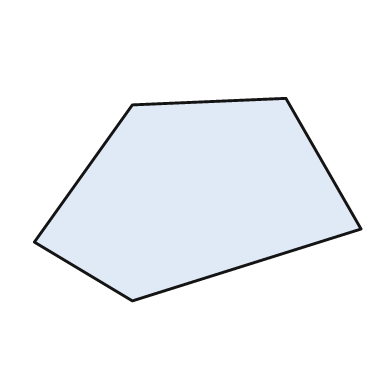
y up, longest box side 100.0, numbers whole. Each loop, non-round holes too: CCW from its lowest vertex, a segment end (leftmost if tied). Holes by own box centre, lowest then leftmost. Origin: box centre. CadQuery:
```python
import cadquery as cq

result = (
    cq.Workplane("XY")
    .moveTo(-20.0, -31.0)
    .lineTo(50.0, -9.0)
    .lineTo(27.0, 31.0)
    .lineTo(-20.0, 29.0)
    .lineTo(-50.0, -13.0)
    .close()
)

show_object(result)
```